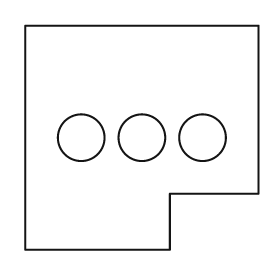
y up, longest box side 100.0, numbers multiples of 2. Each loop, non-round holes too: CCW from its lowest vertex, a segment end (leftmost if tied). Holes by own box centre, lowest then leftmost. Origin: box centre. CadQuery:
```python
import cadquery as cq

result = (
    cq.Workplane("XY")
    .moveTo(-50.0, -48.0)
    .lineTo(12.0, -48.0)
    .lineTo(12.0, -24.0)
    .lineTo(50.0, -24.0)
    .lineTo(50.0, 48.0)
    .lineTo(-50.0, 48.0)
    .close()
    .moveTo(-26.0, 0.0)
    .circle(10.0)
    .moveTo(0.0, 0.0)
    .circle(10.0)
    .moveTo(26.0, 0.0)
    .circle(10.0)
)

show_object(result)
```